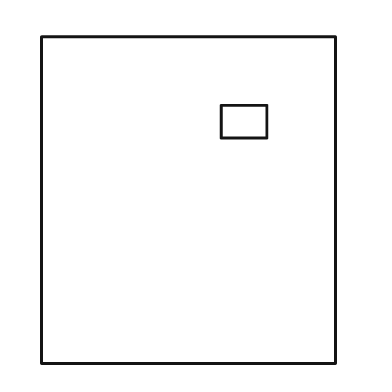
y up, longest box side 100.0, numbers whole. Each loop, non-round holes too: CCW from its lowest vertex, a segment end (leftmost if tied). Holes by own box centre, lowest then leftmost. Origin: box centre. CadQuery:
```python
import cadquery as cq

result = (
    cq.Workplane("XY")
    .moveTo(-45.0, -50.0)
    .lineTo(45.0, -50.0)
    .lineTo(45.0, 50.0)
    .lineTo(-45.0, 50.0)
    .close()
    .moveTo(10.0, 19.0)
    .lineTo(24.0, 19.0)
    .lineTo(24.0, 29.0)
    .lineTo(10.0, 29.0)
    .close()
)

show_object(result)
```